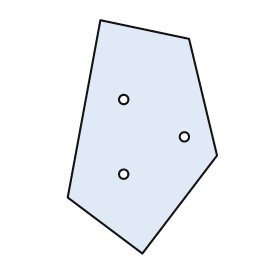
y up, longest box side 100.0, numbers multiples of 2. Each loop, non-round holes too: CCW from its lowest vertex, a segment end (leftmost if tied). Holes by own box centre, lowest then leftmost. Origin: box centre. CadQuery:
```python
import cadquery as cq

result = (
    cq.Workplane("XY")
    .moveTo(0.0, -50.0)
    .lineTo(32.0, -8.0)
    .lineTo(20.0, 42.0)
    .lineTo(-18.0, 50.0)
    .lineTo(-32.0, -26.0)
    .close()
    .moveTo(-8.0, -16.0)
    .circle(2.0)
    .moveTo(18.0, 0.0)
    .circle(2.0)
    .moveTo(-8.0, 16.0)
    .circle(2.0)
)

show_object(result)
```